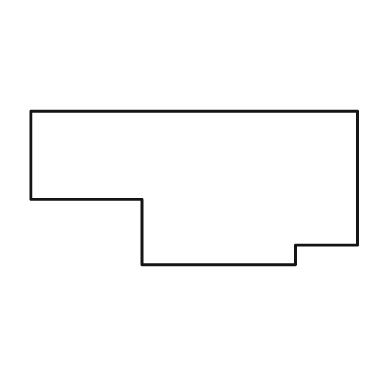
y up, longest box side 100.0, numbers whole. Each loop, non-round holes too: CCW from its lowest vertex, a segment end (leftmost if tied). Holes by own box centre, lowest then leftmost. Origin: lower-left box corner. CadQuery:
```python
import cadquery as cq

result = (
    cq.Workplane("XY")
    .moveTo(34.0, 0.0)
    .lineTo(81.0, 0.0)
    .lineTo(81.0, 6.0)
    .lineTo(100.0, 6.0)
    .lineTo(100.0, 47.0)
    .lineTo(0.0, 47.0)
    .lineTo(0.0, 20.0)
    .lineTo(34.0, 20.0)
    .close()
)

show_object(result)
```